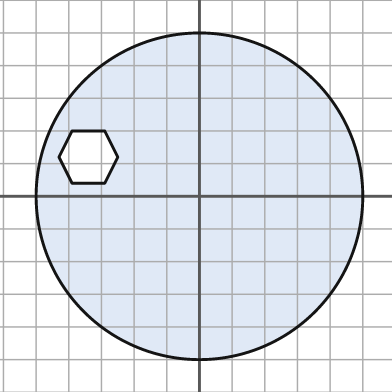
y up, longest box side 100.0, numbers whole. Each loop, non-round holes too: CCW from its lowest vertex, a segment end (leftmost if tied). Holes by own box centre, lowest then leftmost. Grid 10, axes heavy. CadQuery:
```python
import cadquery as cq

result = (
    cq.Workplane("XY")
    .moveTo(0.0, 0.0)
    .circle(50.0)
    .moveTo(-39.0, 4.0)
    .lineTo(-29.0, 4.0)
    .lineTo(-25.0, 12.0)
    .lineTo(-29.0, 20.0)
    .lineTo(-39.0, 20.0)
    .lineTo(-43.0, 12.0)
    .close()
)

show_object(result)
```